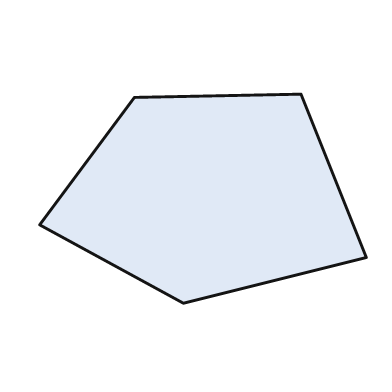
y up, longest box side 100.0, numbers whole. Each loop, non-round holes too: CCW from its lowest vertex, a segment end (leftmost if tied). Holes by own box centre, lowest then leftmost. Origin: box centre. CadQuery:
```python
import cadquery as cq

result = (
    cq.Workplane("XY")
    .moveTo(-6.0, -32.0)
    .lineTo(50.0, -18.0)
    .lineTo(30.0, 32.0)
    .lineTo(-21.0, 31.0)
    .lineTo(-50.0, -8.0)
    .close()
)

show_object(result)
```